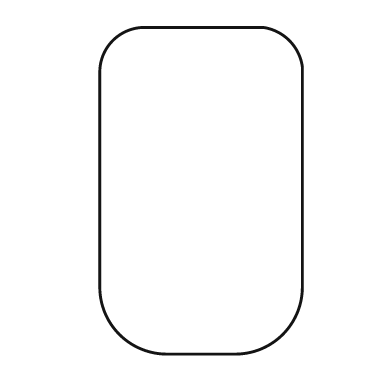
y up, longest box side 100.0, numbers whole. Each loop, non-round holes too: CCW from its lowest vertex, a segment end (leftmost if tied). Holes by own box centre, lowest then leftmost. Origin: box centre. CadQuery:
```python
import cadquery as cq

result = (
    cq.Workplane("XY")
    .moveTo(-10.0, -50.0)
    .lineTo(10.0, -50.0)
    .threePointArc((25.0, -44.0), (31.0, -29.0))
    .lineTo(31.0, 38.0)
    .threePointArc((27.0, 46.0), (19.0, 50.0))
    .lineTo(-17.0, 50.0)
    .threePointArc((-27.0, 46.0), (-31.0, 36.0))
    .lineTo(-31.0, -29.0)
    .threePointArc((-25.0, -44.0), (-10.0, -50.0))
    .close()
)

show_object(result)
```